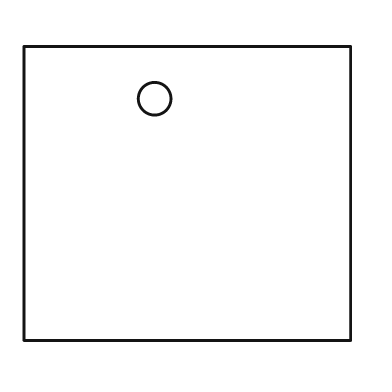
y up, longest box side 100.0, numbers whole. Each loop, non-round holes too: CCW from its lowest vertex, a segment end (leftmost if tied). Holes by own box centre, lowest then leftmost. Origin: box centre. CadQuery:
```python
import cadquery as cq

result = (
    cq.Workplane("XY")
    .moveTo(-50.0, -45.0)
    .lineTo(50.0, -45.0)
    .lineTo(50.0, 45.0)
    .lineTo(-50.0, 45.0)
    .close()
    .moveTo(-10.0, 29.0)
    .circle(5.0)
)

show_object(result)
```